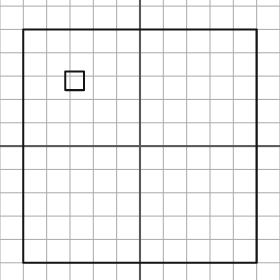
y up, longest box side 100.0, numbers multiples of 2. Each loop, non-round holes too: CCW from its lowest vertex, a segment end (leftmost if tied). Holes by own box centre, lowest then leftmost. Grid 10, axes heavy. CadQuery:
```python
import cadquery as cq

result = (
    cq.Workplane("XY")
    .moveTo(-50.0, -50.0)
    .lineTo(50.0, -50.0)
    .lineTo(50.0, 50.0)
    .lineTo(-50.0, 50.0)
    .close()
    .moveTo(-32.0, 24.0)
    .lineTo(-24.0, 24.0)
    .lineTo(-24.0, 32.0)
    .lineTo(-32.0, 32.0)
    .close()
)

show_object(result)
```